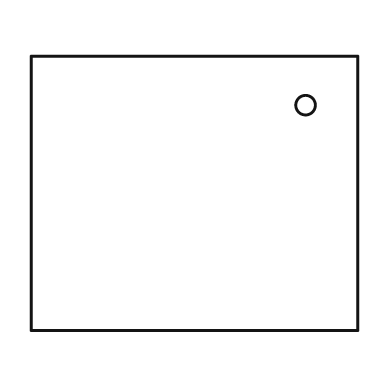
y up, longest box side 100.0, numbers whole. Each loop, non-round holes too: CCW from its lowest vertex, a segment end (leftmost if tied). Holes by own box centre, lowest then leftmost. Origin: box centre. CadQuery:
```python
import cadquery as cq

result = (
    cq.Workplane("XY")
    .moveTo(-50.0, -42.0)
    .lineTo(50.0, -42.0)
    .lineTo(50.0, 42.0)
    .lineTo(-50.0, 42.0)
    .close()
    .moveTo(34.0, 27.0)
    .circle(3.0)
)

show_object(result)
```